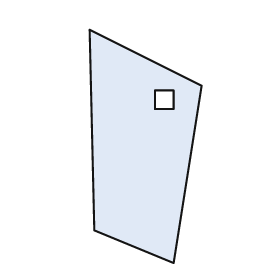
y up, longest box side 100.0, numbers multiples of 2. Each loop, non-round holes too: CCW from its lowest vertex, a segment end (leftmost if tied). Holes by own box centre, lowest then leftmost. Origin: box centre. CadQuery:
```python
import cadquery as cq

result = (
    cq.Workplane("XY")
    .moveTo(12.0, -50.0)
    .lineTo(24.0, 26.0)
    .lineTo(-24.0, 50.0)
    .lineTo(-22.0, -36.0)
    .close()
    .moveTo(4.0, 16.0)
    .lineTo(12.0, 16.0)
    .lineTo(12.0, 24.0)
    .lineTo(4.0, 24.0)
    .close()
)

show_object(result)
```